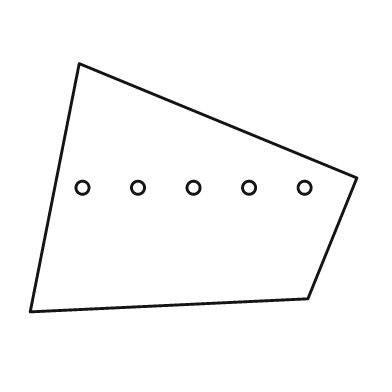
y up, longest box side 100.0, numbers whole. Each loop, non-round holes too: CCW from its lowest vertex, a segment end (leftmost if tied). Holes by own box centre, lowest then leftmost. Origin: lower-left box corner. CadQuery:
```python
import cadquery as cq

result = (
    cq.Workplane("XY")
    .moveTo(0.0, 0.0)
    .lineTo(85.0, 4.0)
    .lineTo(100.0, 41.0)
    .lineTo(15.0, 76.0)
    .close()
    .moveTo(16.0, 38.0)
    .circle(2.0)
    .moveTo(33.0, 38.0)
    .circle(2.0)
    .moveTo(50.0, 38.0)
    .circle(2.0)
    .moveTo(67.0, 38.0)
    .circle(2.0)
    .moveTo(84.0, 38.0)
    .circle(2.0)
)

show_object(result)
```